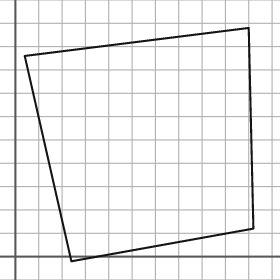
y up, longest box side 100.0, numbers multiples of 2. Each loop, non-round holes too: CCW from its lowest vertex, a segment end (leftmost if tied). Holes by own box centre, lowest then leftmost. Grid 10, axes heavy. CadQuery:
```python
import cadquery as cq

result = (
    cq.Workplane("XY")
    .moveTo(24.0, -2.0)
    .lineTo(102.0, 12.0)
    .lineTo(100.0, 98.0)
    .lineTo(4.0, 86.0)
    .close()
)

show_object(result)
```